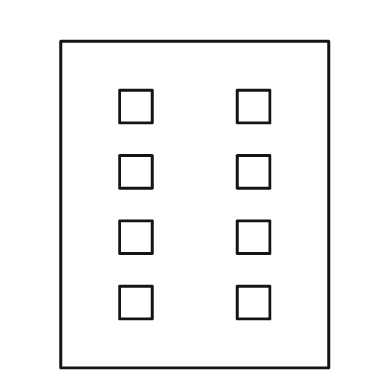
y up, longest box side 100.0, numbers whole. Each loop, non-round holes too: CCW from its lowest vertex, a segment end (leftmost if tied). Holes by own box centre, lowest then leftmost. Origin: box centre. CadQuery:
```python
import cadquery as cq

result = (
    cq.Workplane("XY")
    .moveTo(-41.0, -50.0)
    .lineTo(41.0, -50.0)
    .lineTo(41.0, 50.0)
    .lineTo(-41.0, 50.0)
    .close()
    .moveTo(-23.0, -35.0)
    .lineTo(-13.0, -35.0)
    .lineTo(-13.0, -25.0)
    .lineTo(-23.0, -25.0)
    .close()
    .moveTo(13.0, -35.0)
    .lineTo(23.0, -35.0)
    .lineTo(23.0, -25.0)
    .lineTo(13.0, -25.0)
    .close()
    .moveTo(-23.0, -15.0)
    .lineTo(-13.0, -15.0)
    .lineTo(-13.0, -5.0)
    .lineTo(-23.0, -5.0)
    .close()
    .moveTo(13.0, -15.0)
    .lineTo(23.0, -15.0)
    .lineTo(23.0, -5.0)
    .lineTo(13.0, -5.0)
    .close()
    .moveTo(-23.0, 5.0)
    .lineTo(-13.0, 5.0)
    .lineTo(-13.0, 15.0)
    .lineTo(-23.0, 15.0)
    .close()
    .moveTo(13.0, 5.0)
    .lineTo(23.0, 5.0)
    .lineTo(23.0, 15.0)
    .lineTo(13.0, 15.0)
    .close()
    .moveTo(-23.0, 25.0)
    .lineTo(-13.0, 25.0)
    .lineTo(-13.0, 35.0)
    .lineTo(-23.0, 35.0)
    .close()
    .moveTo(13.0, 25.0)
    .lineTo(23.0, 25.0)
    .lineTo(23.0, 35.0)
    .lineTo(13.0, 35.0)
    .close()
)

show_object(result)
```